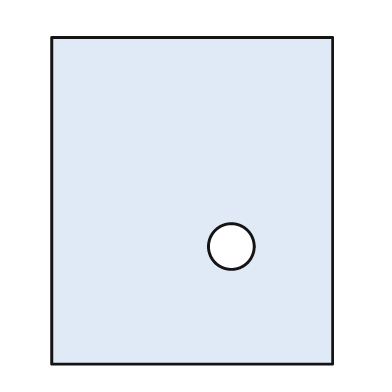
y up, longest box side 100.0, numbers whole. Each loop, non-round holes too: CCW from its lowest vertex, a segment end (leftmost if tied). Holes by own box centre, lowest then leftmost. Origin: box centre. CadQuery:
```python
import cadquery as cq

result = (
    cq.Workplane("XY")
    .moveTo(-43.0, -50.0)
    .lineTo(43.0, -50.0)
    .lineTo(43.0, 50.0)
    .lineTo(-43.0, 50.0)
    .close()
    .moveTo(12.0, -14.0)
    .circle(7.0)
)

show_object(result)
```